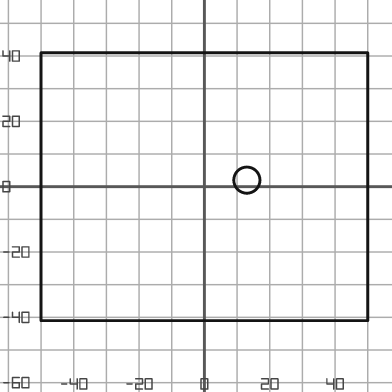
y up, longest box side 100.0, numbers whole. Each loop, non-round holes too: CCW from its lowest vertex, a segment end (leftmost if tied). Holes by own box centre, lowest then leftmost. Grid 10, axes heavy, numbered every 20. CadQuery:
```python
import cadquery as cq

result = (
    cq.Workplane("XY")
    .moveTo(-50.0, -41.0)
    .lineTo(50.0, -41.0)
    .lineTo(50.0, 41.0)
    .lineTo(-50.0, 41.0)
    .close()
    .moveTo(13.0, 2.0)
    .circle(4.0)
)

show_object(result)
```